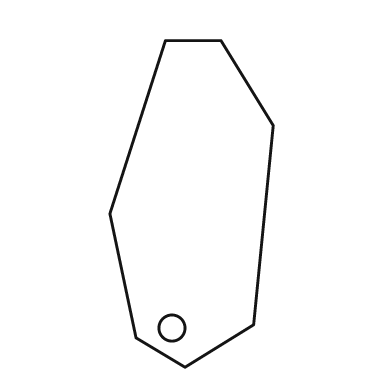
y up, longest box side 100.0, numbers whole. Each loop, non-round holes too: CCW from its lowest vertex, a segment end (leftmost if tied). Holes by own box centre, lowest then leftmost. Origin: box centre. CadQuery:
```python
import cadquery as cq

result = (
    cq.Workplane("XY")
    .moveTo(-2.0, -50.0)
    .lineTo(19.0, -37.0)
    .lineTo(25.0, 24.0)
    .lineTo(9.0, 50.0)
    .lineTo(-8.0, 50.0)
    .lineTo(-25.0, -3.0)
    .lineTo(-17.0, -41.0)
    .close()
    .moveTo(-6.0, -38.0)
    .circle(4.0)
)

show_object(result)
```